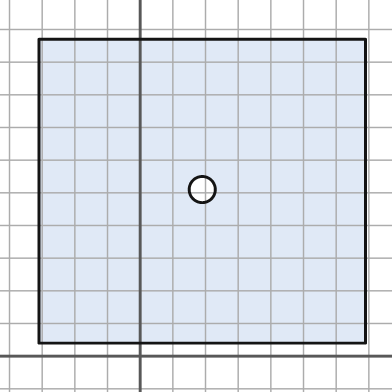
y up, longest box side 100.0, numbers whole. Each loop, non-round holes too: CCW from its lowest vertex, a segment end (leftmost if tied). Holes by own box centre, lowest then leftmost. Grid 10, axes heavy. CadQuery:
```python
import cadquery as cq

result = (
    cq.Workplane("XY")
    .moveTo(-31.0, 4.0)
    .lineTo(69.0, 4.0)
    .lineTo(69.0, 97.0)
    .lineTo(-31.0, 97.0)
    .close()
    .moveTo(19.0, 51.0)
    .circle(4.0)
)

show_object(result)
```